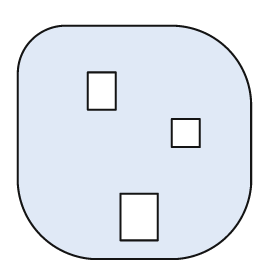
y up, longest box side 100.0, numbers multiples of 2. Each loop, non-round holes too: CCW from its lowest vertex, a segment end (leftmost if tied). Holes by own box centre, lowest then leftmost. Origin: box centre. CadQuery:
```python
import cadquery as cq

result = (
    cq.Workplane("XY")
    .moveTo(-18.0, -50.0)
    .lineTo(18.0, -50.0)
    .threePointArc((40.0, -40.0), (50.0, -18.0))
    .lineTo(50.0, 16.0)
    .threePointArc((40.0, 40.0), (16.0, 50.0))
    .lineTo(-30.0, 50.0)
    .threePointArc((-44.0, 44.0), (-50.0, 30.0))
    .lineTo(-50.0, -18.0)
    .threePointArc((-40.0, -40.0), (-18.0, -50.0))
    .close()
    .moveTo(-6.0, -42.0)
    .lineTo(10.0, -42.0)
    .lineTo(10.0, -22.0)
    .lineTo(-6.0, -22.0)
    .close()
    .moveTo(16.0, -2.0)
    .lineTo(28.0, -2.0)
    .lineTo(28.0, 10.0)
    .lineTo(16.0, 10.0)
    .close()
    .moveTo(-20.0, 14.0)
    .lineTo(-8.0, 14.0)
    .lineTo(-8.0, 30.0)
    .lineTo(-20.0, 30.0)
    .close()
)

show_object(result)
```